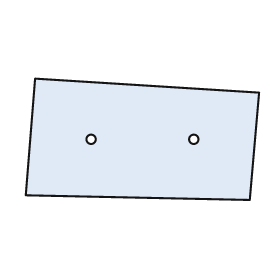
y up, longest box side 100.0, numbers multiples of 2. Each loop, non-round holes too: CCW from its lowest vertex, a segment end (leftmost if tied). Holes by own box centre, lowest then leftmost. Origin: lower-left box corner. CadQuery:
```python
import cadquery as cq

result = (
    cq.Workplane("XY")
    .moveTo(96.0, 0.0)
    .lineTo(100.0, 46.0)
    .lineTo(4.0, 52.0)
    .lineTo(0.0, 2.0)
    .close()
    .moveTo(28.0, 26.0)
    .circle(2.0)
    .moveTo(72.0, 26.0)
    .circle(2.0)
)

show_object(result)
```